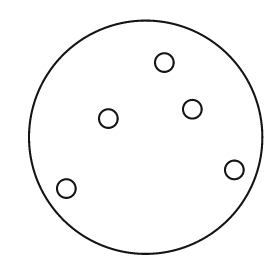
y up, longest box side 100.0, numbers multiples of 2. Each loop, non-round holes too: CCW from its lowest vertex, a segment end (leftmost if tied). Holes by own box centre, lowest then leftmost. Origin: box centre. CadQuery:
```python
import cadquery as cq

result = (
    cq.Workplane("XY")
    .moveTo(0.0, 0.0)
    .circle(50.0)
    .moveTo(-34.0, -22.0)
    .circle(4.0)
    .moveTo(38.0, -14.0)
    .circle(4.0)
    .moveTo(-16.0, 8.0)
    .circle(4.0)
    .moveTo(20.0, 12.0)
    .circle(4.0)
    .moveTo(8.0, 32.0)
    .circle(4.0)
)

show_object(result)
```